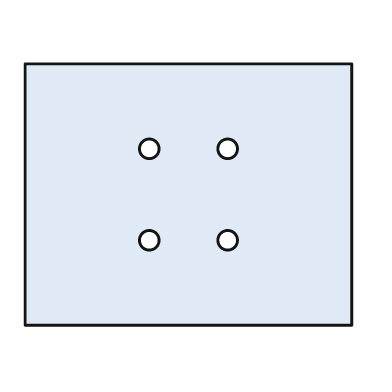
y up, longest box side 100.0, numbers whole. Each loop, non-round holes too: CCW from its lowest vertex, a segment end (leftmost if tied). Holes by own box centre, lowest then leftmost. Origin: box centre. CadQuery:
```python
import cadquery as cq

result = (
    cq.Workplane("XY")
    .moveTo(-50.0, -40.0)
    .lineTo(50.0, -40.0)
    .lineTo(50.0, 40.0)
    .lineTo(-50.0, 40.0)
    .close()
    .moveTo(-12.0, -14.0)
    .circle(3.0)
    .moveTo(12.0, -14.0)
    .circle(3.0)
    .moveTo(-12.0, 14.0)
    .circle(3.0)
    .moveTo(12.0, 14.0)
    .circle(3.0)
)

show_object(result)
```